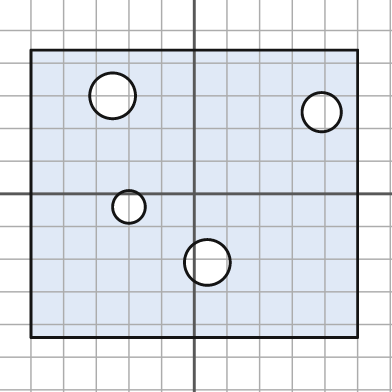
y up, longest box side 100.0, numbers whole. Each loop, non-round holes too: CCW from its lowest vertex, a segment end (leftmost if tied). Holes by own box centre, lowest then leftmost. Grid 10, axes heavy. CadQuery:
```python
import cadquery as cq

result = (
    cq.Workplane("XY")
    .moveTo(-50.0, -44.0)
    .lineTo(50.0, -44.0)
    .lineTo(50.0, 44.0)
    .lineTo(-50.0, 44.0)
    .close()
    .moveTo(4.0, -21.0)
    .circle(7.0)
    .moveTo(-20.0, -4.0)
    .circle(5.0)
    .moveTo(39.0, 25.0)
    .circle(6.0)
    .moveTo(-25.0, 30.0)
    .circle(7.0)
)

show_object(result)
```